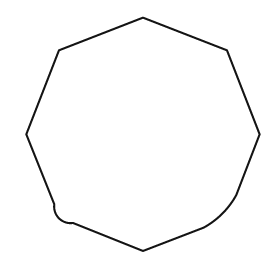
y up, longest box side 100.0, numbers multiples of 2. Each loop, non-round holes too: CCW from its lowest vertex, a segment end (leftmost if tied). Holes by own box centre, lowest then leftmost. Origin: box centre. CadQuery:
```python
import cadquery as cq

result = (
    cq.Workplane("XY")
    .moveTo(0.0, -50.0)
    .lineTo(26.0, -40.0)
    .threePointArc((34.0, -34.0), (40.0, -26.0))
    .lineTo(50.0, 0.0)
    .lineTo(36.0, 36.0)
    .lineTo(0.0, 50.0)
    .lineTo(-36.0, 36.0)
    .lineTo(-50.0, 0.0)
    .lineTo(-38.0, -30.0)
    .threePointArc((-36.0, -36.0), (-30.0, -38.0))
    .close()
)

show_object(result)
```